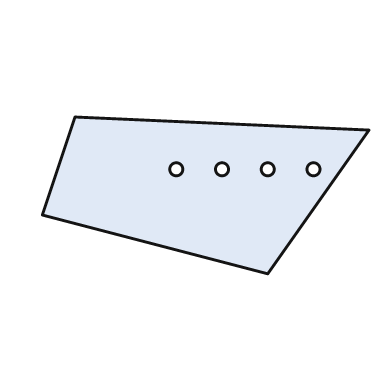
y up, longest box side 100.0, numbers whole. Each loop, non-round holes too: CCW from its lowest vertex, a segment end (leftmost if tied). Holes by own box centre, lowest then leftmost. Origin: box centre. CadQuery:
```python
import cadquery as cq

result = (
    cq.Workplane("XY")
    .moveTo(19.0, -24.0)
    .lineTo(50.0, 20.0)
    .lineTo(-40.0, 24.0)
    .lineTo(-50.0, -6.0)
    .close()
    .moveTo(-9.0, 8.0)
    .circle(2.0)
    .moveTo(5.0, 8.0)
    .circle(2.0)
    .moveTo(19.0, 8.0)
    .circle(2.0)
    .moveTo(33.0, 8.0)
    .circle(2.0)
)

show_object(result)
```